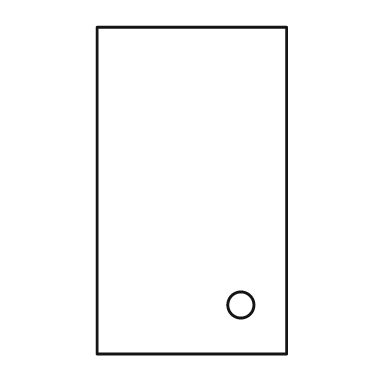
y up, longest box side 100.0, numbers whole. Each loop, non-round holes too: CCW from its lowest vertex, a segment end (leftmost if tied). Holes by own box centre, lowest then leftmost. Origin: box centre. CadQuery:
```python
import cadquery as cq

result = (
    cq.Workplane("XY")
    .moveTo(-29.0, -50.0)
    .lineTo(29.0, -50.0)
    .lineTo(29.0, 50.0)
    .lineTo(-29.0, 50.0)
    .close()
    .moveTo(15.0, -35.0)
    .circle(4.0)
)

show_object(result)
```